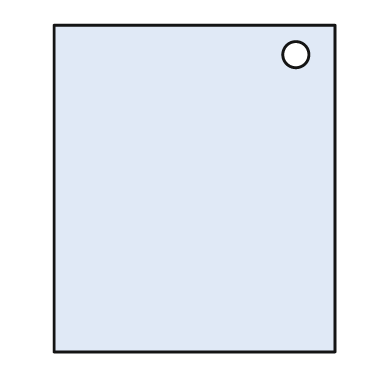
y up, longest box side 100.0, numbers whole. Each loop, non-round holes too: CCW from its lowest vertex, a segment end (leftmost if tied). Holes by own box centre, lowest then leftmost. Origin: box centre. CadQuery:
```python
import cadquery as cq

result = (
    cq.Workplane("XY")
    .moveTo(-43.0, -50.0)
    .lineTo(43.0, -50.0)
    .lineTo(43.0, 50.0)
    .lineTo(-43.0, 50.0)
    .close()
    .moveTo(31.0, 41.0)
    .circle(4.0)
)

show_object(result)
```